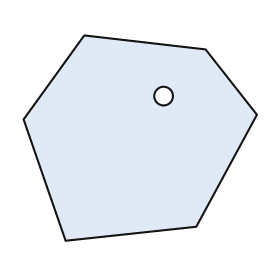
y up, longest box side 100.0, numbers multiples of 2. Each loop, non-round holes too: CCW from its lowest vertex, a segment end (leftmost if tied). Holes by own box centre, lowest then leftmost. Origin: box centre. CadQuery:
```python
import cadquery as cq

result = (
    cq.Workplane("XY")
    .moveTo(-32.0, -44.0)
    .lineTo(24.0, -38.0)
    .lineTo(50.0, 10.0)
    .lineTo(28.0, 38.0)
    .lineTo(-24.0, 44.0)
    .lineTo(-50.0, 8.0)
    .close()
    .moveTo(10.0, 18.0)
    .circle(4.0)
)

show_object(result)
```